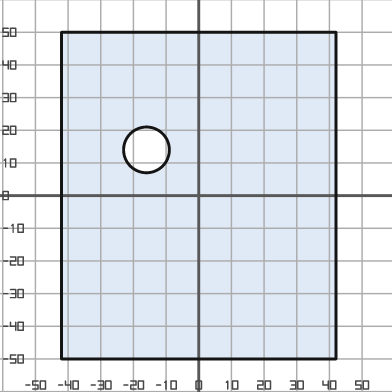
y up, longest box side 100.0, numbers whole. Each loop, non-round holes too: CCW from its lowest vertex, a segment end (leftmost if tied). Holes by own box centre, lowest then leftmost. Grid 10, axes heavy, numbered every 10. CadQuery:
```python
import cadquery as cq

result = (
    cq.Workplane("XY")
    .moveTo(-42.0, -50.0)
    .lineTo(42.0, -50.0)
    .lineTo(42.0, 50.0)
    .lineTo(-42.0, 50.0)
    .close()
    .moveTo(-16.0, 14.0)
    .circle(7.0)
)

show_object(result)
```